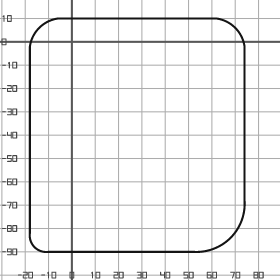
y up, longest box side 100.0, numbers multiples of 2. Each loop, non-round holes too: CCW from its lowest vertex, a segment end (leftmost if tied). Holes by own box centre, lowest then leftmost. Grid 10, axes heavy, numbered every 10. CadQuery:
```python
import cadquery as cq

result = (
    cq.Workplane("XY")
    .moveTo(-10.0, -90.0)
    .lineTo(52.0, -90.0)
    .threePointArc((68.0, -84.0), (74.0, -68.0))
    .lineTo(74.0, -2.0)
    .threePointArc((70.0, 6.0), (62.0, 10.0))
    .lineTo(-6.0, 10.0)
    .threePointArc((-14.0, 6.0), (-18.0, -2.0))
    .lineTo(-18.0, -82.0)
    .threePointArc((-16.0, -88.0), (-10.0, -90.0))
    .close()
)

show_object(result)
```